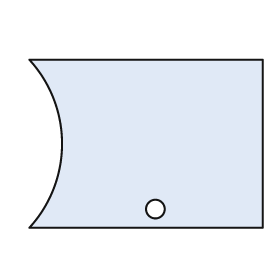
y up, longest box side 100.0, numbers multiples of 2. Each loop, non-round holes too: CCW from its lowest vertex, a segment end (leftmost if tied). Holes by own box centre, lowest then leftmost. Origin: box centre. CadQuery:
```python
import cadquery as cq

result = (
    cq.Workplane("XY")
    .moveTo(-50.0, -36.0)
    .lineTo(50.0, -36.0)
    .lineTo(50.0, 36.0)
    .lineTo(-50.0, 36.0)
    .threePointArc((-36.0, 0.0), (-50.0, -36.0))
    .close()
    .moveTo(4.0, -28.0)
    .circle(4.0)
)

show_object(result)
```